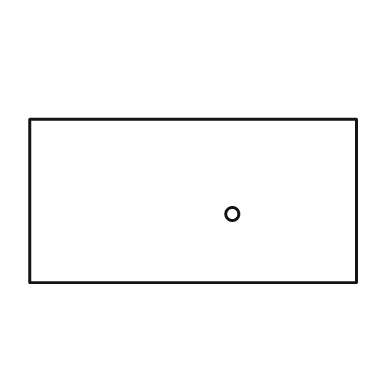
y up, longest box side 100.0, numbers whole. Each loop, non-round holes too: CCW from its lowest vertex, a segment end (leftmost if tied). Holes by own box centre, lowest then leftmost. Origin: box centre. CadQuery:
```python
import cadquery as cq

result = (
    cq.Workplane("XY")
    .moveTo(-50.0, -25.0)
    .lineTo(50.0, -25.0)
    .lineTo(50.0, 25.0)
    .lineTo(-50.0, 25.0)
    .close()
    .moveTo(12.0, -4.0)
    .circle(2.0)
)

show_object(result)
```